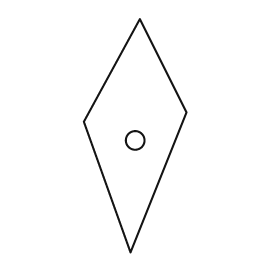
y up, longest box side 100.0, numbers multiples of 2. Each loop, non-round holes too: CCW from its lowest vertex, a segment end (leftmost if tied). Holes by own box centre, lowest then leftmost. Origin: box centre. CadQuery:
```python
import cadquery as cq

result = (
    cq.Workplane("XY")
    .moveTo(-2.0, -50.0)
    .lineTo(22.0, 10.0)
    .lineTo(2.0, 50.0)
    .lineTo(-22.0, 6.0)
    .close()
    .moveTo(0.0, -2.0)
    .circle(4.0)
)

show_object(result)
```